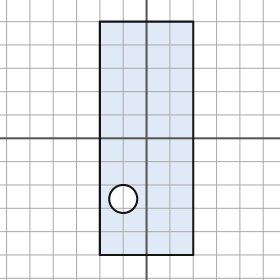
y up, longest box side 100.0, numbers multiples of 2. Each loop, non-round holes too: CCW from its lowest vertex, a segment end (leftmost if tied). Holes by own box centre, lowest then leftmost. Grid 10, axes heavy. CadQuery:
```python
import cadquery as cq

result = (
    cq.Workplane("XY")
    .moveTo(-20.0, -50.0)
    .lineTo(20.0, -50.0)
    .lineTo(20.0, 50.0)
    .lineTo(-20.0, 50.0)
    .close()
    .moveTo(-10.0, -26.0)
    .circle(6.0)
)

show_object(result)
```